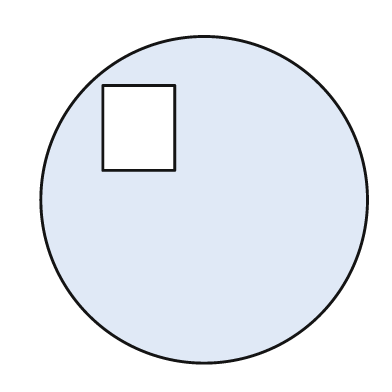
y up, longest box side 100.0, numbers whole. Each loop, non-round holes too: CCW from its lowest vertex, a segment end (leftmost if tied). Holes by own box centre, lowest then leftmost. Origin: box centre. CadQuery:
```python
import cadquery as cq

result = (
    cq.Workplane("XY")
    .moveTo(0.0, 0.0)
    .circle(50.0)
    .moveTo(-31.0, 9.0)
    .lineTo(-9.0, 9.0)
    .lineTo(-9.0, 35.0)
    .lineTo(-31.0, 35.0)
    .close()
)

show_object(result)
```